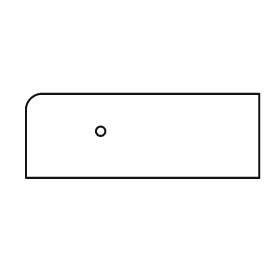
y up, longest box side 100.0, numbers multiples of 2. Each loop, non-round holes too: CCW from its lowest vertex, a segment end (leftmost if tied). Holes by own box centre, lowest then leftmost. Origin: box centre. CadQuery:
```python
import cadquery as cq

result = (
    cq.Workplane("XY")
    .moveTo(-50.0, -18.0)
    .lineTo(50.0, -18.0)
    .lineTo(50.0, 18.0)
    .lineTo(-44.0, 18.0)
    .threePointArc((-48.0, 16.0), (-50.0, 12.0))
    .close()
    .moveTo(-18.0, 2.0)
    .circle(2.0)
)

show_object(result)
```